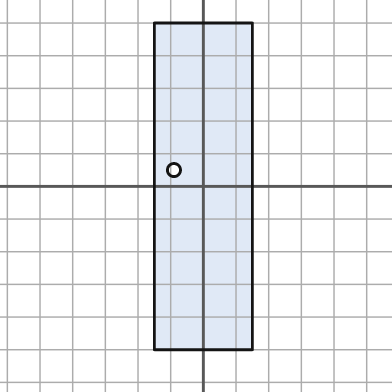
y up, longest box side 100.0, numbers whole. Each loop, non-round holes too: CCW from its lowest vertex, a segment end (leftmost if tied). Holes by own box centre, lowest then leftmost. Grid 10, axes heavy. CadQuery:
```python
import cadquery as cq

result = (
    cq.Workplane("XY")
    .moveTo(-15.0, -50.0)
    .lineTo(15.0, -50.0)
    .lineTo(15.0, 50.0)
    .lineTo(-15.0, 50.0)
    .close()
    .moveTo(-9.0, 5.0)
    .circle(2.0)
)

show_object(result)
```